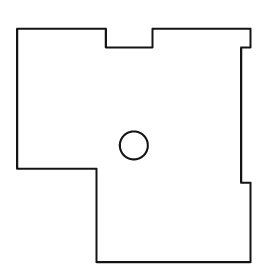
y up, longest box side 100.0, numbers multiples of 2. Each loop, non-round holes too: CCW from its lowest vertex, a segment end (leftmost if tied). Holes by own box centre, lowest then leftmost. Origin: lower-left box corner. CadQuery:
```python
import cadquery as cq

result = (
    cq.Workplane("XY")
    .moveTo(34.0, 0.0)
    .lineTo(100.0, 0.0)
    .lineTo(100.0, 34.0)
    .lineTo(96.0, 34.0)
    .lineTo(96.0, 92.0)
    .lineTo(100.0, 92.0)
    .lineTo(100.0, 100.0)
    .lineTo(58.0, 100.0)
    .lineTo(58.0, 92.0)
    .lineTo(38.0, 92.0)
    .lineTo(38.0, 100.0)
    .lineTo(0.0, 100.0)
    .lineTo(0.0, 40.0)
    .lineTo(34.0, 40.0)
    .close()
    .moveTo(50.0, 50.0)
    .circle(6.0)
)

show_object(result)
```